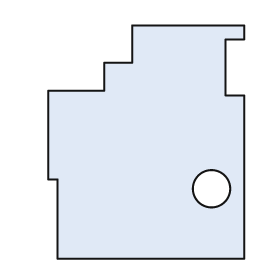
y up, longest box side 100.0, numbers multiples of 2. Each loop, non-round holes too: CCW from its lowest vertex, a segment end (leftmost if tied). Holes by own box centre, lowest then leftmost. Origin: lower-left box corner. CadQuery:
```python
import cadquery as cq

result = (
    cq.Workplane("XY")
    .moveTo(4.0, 0.0)
    .lineTo(84.0, 0.0)
    .lineTo(84.0, 70.0)
    .lineTo(76.0, 70.0)
    .lineTo(76.0, 94.0)
    .lineTo(84.0, 94.0)
    .lineTo(84.0, 100.0)
    .lineTo(36.0, 100.0)
    .lineTo(36.0, 84.0)
    .lineTo(24.0, 84.0)
    .lineTo(24.0, 72.0)
    .lineTo(0.0, 72.0)
    .lineTo(0.0, 34.0)
    .lineTo(4.0, 34.0)
    .close()
    .moveTo(70.0, 30.0)
    .circle(8.0)
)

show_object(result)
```